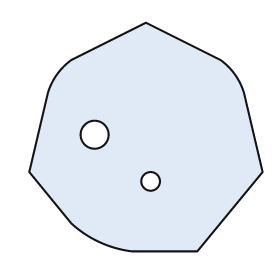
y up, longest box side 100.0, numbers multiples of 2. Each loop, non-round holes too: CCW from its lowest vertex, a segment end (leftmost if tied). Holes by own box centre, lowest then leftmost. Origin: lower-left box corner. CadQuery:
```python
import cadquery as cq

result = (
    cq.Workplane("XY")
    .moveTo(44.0, 0.0)
    .lineTo(72.0, 0.0)
    .lineTo(100.0, 34.0)
    .lineTo(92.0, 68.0)
    .threePointArc((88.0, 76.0), (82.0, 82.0))
    .lineTo(50.0, 98.0)
    .lineTo(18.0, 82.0)
    .threePointArc((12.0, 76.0), (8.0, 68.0))
    .lineTo(0.0, 34.0)
    .lineTo(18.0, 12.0)
    .threePointArc((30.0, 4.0), (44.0, 0.0))
    .close()
    .moveTo(52.0, 30.0)
    .circle(4.0)
    .moveTo(28.0, 50.0)
    .circle(6.0)
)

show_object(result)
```